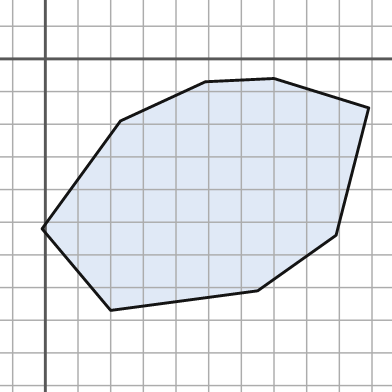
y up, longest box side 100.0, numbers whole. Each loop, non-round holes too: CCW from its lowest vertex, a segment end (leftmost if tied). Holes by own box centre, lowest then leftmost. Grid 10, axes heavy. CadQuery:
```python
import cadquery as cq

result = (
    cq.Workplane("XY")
    .moveTo(20.0, -77.0)
    .lineTo(65.0, -71.0)
    .lineTo(89.0, -54.0)
    .lineTo(99.0, -15.0)
    .lineTo(70.0, -6.0)
    .lineTo(49.0, -7.0)
    .lineTo(23.0, -19.0)
    .lineTo(-1.0, -52.0)
    .close()
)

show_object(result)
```